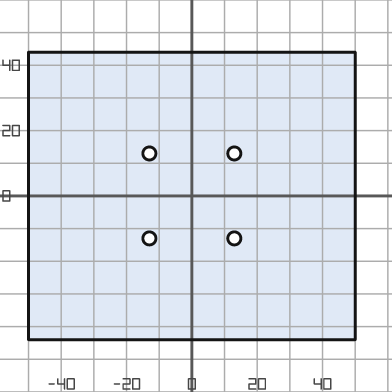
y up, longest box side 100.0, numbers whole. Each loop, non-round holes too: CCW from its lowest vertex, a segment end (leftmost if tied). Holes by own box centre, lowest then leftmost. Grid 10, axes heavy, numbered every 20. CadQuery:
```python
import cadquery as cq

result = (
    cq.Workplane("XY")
    .moveTo(-50.0, -44.0)
    .lineTo(50.0, -44.0)
    .lineTo(50.0, 44.0)
    .lineTo(-50.0, 44.0)
    .close()
    .moveTo(-13.0, -13.0)
    .circle(2.0)
    .moveTo(13.0, -13.0)
    .circle(2.0)
    .moveTo(-13.0, 13.0)
    .circle(2.0)
    .moveTo(13.0, 13.0)
    .circle(2.0)
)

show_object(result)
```